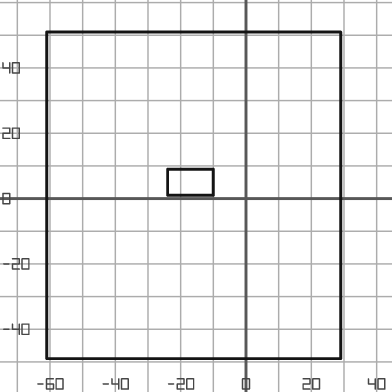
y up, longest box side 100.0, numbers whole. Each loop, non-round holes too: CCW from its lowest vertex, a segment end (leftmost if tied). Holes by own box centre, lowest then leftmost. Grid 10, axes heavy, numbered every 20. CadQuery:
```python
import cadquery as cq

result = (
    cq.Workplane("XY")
    .moveTo(-61.0, -49.0)
    .lineTo(29.0, -49.0)
    .lineTo(29.0, 51.0)
    .lineTo(-61.0, 51.0)
    .close()
    .moveTo(-24.0, 1.0)
    .lineTo(-10.0, 1.0)
    .lineTo(-10.0, 9.0)
    .lineTo(-24.0, 9.0)
    .close()
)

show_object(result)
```